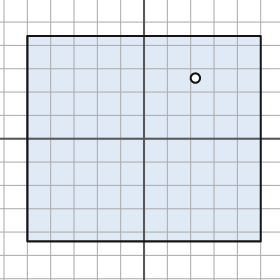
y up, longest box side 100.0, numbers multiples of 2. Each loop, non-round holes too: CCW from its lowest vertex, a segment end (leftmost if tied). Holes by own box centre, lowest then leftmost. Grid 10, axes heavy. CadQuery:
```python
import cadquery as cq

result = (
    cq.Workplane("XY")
    .moveTo(-50.0, -44.0)
    .lineTo(50.0, -44.0)
    .lineTo(50.0, 44.0)
    .lineTo(-50.0, 44.0)
    .close()
    .moveTo(22.0, 26.0)
    .circle(2.0)
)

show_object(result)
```